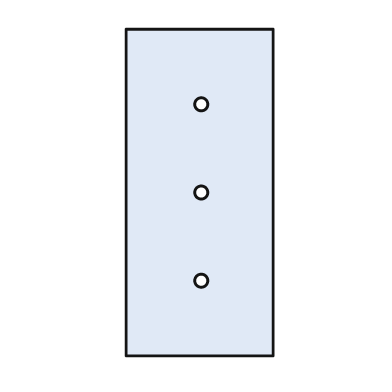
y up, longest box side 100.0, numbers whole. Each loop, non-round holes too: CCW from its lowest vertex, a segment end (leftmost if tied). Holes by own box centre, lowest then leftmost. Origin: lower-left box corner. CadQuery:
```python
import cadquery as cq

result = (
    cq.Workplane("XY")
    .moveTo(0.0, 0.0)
    .lineTo(45.0, 0.0)
    .lineTo(45.0, 100.0)
    .lineTo(0.0, 100.0)
    .close()
    .moveTo(23.0, 23.0)
    .circle(2.0)
    .moveTo(23.0, 50.0)
    .circle(2.0)
    .moveTo(23.0, 77.0)
    .circle(2.0)
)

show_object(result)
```